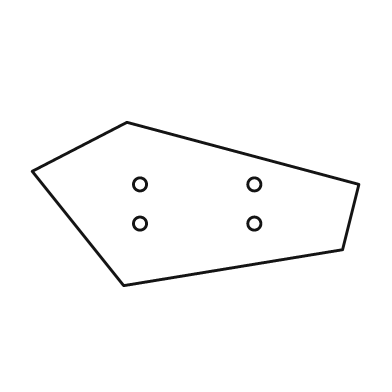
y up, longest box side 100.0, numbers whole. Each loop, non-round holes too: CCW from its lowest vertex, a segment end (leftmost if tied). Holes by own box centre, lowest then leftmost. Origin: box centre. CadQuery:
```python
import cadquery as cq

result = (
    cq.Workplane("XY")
    .moveTo(-22.0, -25.0)
    .lineTo(45.0, -14.0)
    .lineTo(50.0, 6.0)
    .lineTo(-21.0, 25.0)
    .lineTo(-50.0, 10.0)
    .close()
    .moveTo(-17.0, -6.0)
    .circle(2.0)
    .moveTo(18.0, -6.0)
    .circle(2.0)
    .moveTo(-17.0, 6.0)
    .circle(2.0)
    .moveTo(18.0, 6.0)
    .circle(2.0)
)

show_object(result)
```